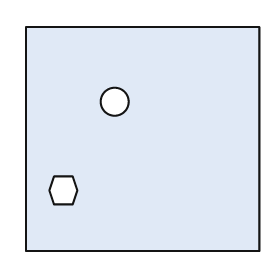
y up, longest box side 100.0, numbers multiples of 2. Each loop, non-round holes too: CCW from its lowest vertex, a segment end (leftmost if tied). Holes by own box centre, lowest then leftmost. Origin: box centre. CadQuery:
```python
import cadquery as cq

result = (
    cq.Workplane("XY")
    .moveTo(-50.0, -48.0)
    .lineTo(50.0, -48.0)
    .lineTo(50.0, 48.0)
    .lineTo(-50.0, 48.0)
    .close()
    .moveTo(-38.0, -28.0)
    .lineTo(-30.0, -28.0)
    .lineTo(-28.0, -22.0)
    .lineTo(-30.0, -16.0)
    .lineTo(-38.0, -16.0)
    .lineTo(-40.0, -22.0)
    .close()
    .moveTo(-12.0, 16.0)
    .circle(6.0)
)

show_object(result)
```